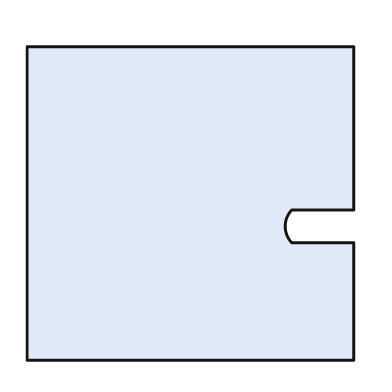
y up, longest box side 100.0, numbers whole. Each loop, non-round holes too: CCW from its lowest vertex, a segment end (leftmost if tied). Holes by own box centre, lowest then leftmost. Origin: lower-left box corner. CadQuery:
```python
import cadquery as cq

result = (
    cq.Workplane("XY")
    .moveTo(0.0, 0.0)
    .lineTo(100.0, 0.0)
    .lineTo(100.0, 36.0)
    .lineTo(81.0, 36.0)
    .threePointArc((79.0, 41.0), (81.0, 46.0))
    .lineTo(100.0, 46.0)
    .lineTo(100.0, 96.0)
    .lineTo(0.0, 96.0)
    .close()
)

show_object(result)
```